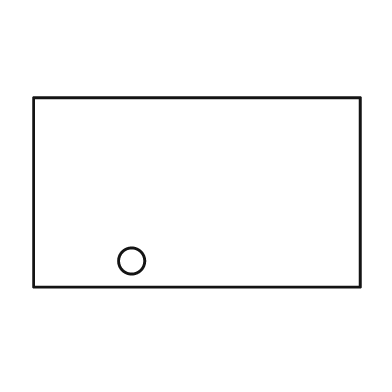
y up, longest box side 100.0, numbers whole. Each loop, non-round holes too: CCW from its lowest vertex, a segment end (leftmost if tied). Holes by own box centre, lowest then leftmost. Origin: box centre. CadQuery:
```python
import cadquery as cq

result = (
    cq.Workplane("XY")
    .moveTo(-50.0, -29.0)
    .lineTo(50.0, -29.0)
    .lineTo(50.0, 29.0)
    .lineTo(-50.0, 29.0)
    .close()
    .moveTo(-20.0, -21.0)
    .circle(4.0)
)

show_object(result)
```